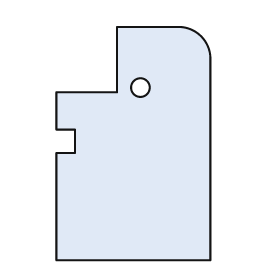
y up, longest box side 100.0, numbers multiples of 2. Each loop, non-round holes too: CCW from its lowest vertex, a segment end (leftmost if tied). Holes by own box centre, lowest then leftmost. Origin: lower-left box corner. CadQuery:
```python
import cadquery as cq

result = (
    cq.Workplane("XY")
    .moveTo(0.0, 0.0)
    .lineTo(66.0, 0.0)
    .lineTo(66.0, 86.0)
    .threePointArc((62.0, 96.0), (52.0, 100.0))
    .lineTo(26.0, 100.0)
    .lineTo(26.0, 72.0)
    .lineTo(0.0, 72.0)
    .lineTo(0.0, 56.0)
    .lineTo(8.0, 56.0)
    .lineTo(8.0, 46.0)
    .lineTo(0.0, 46.0)
    .close()
    .moveTo(36.0, 74.0)
    .circle(4.0)
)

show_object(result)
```